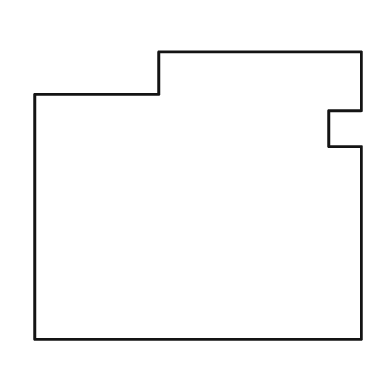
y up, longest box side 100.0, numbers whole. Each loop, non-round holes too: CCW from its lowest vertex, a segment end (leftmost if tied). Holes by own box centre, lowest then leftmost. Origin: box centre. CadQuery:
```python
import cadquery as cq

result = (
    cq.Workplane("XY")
    .moveTo(-50.0, -44.0)
    .lineTo(50.0, -44.0)
    .lineTo(50.0, 15.0)
    .lineTo(40.0, 15.0)
    .lineTo(40.0, 26.0)
    .lineTo(50.0, 26.0)
    .lineTo(50.0, 44.0)
    .lineTo(-12.0, 44.0)
    .lineTo(-12.0, 31.0)
    .lineTo(-50.0, 31.0)
    .close()
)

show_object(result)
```